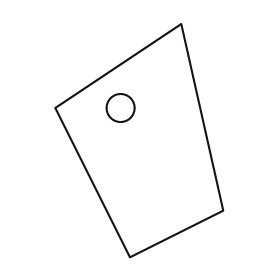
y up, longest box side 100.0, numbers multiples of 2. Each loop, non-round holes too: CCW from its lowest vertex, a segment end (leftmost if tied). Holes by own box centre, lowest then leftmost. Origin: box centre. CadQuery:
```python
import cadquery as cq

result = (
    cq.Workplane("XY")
    .moveTo(-4.0, -50.0)
    .lineTo(36.0, -30.0)
    .lineTo(18.0, 50.0)
    .lineTo(-36.0, 14.0)
    .close()
    .moveTo(-8.0, 14.0)
    .circle(6.0)
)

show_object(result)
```